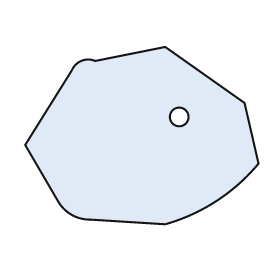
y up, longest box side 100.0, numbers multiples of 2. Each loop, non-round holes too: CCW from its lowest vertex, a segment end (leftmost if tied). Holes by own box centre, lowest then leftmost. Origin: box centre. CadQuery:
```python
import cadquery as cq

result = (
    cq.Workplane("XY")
    .moveTo(10.0, -38.0)
    .threePointArc((32.0, -28.0), (50.0, -12.0))
    .lineTo(44.0, 14.0)
    .lineTo(10.0, 38.0)
    .lineTo(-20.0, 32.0)
    .threePointArc((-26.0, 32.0), (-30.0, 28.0))
    .lineTo(-50.0, -4.0)
    .lineTo(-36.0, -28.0)
    .threePointArc((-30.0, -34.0), (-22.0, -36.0))
    .close()
    .moveTo(16.0, 8.0)
    .circle(4.0)
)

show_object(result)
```